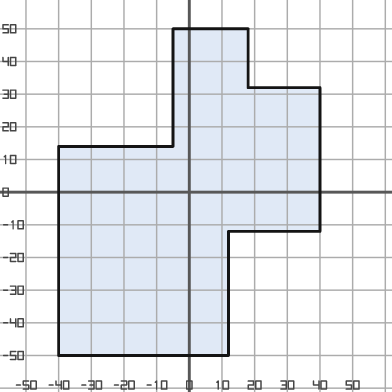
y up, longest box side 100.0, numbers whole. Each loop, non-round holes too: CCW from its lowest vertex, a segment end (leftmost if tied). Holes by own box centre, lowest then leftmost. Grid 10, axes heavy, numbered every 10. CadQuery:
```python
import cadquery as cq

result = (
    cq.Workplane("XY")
    .moveTo(-40.0, -50.0)
    .lineTo(12.0, -50.0)
    .lineTo(12.0, -12.0)
    .lineTo(40.0, -12.0)
    .lineTo(40.0, 32.0)
    .lineTo(18.0, 32.0)
    .lineTo(18.0, 50.0)
    .lineTo(-5.0, 50.0)
    .lineTo(-5.0, 14.0)
    .lineTo(-40.0, 14.0)
    .close()
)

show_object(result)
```